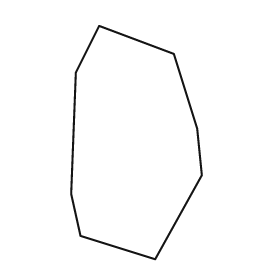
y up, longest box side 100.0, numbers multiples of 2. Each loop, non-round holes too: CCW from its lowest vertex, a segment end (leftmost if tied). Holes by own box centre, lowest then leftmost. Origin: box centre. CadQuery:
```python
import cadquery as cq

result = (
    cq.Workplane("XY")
    .moveTo(8.0, -50.0)
    .lineTo(28.0, -14.0)
    .lineTo(26.0, 6.0)
    .lineTo(16.0, 38.0)
    .lineTo(-16.0, 50.0)
    .lineTo(-26.0, 30.0)
    .lineTo(-28.0, -22.0)
    .lineTo(-24.0, -40.0)
    .close()
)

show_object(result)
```